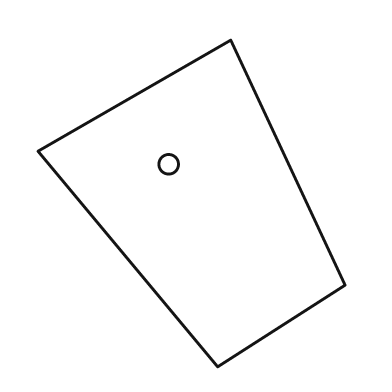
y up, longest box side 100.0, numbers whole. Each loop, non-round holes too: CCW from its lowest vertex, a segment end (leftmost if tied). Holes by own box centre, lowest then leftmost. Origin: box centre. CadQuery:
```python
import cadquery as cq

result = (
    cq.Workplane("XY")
    .moveTo(8.0, -50.0)
    .lineTo(47.0, -25.0)
    .lineTo(12.0, 50.0)
    .lineTo(-47.0, 16.0)
    .close()
    .moveTo(-7.0, 12.0)
    .circle(3.0)
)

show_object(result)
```